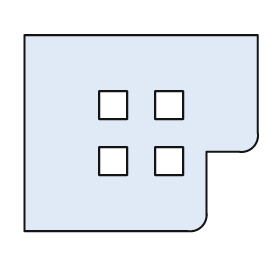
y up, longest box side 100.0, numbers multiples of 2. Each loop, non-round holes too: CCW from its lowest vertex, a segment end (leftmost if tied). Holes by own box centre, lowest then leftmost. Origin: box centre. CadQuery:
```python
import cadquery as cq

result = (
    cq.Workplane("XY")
    .moveTo(-50.0, -42.0)
    .lineTo(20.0, -42.0)
    .threePointArc((26.0, -40.0), (28.0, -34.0))
    .lineTo(28.0, -8.0)
    .lineTo(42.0, -8.0)
    .threePointArc((48.0, -6.0), (50.0, 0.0))
    .lineTo(50.0, 42.0)
    .lineTo(-50.0, 42.0)
    .close()
    .moveTo(-18.0, -18.0)
    .lineTo(-6.0, -18.0)
    .lineTo(-6.0, -6.0)
    .lineTo(-18.0, -6.0)
    .close()
    .moveTo(6.0, -18.0)
    .lineTo(18.0, -18.0)
    .lineTo(18.0, -6.0)
    .lineTo(6.0, -6.0)
    .close()
    .moveTo(-18.0, 6.0)
    .lineTo(-6.0, 6.0)
    .lineTo(-6.0, 18.0)
    .lineTo(-18.0, 18.0)
    .close()
    .moveTo(6.0, 6.0)
    .lineTo(18.0, 6.0)
    .lineTo(18.0, 18.0)
    .lineTo(6.0, 18.0)
    .close()
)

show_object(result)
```